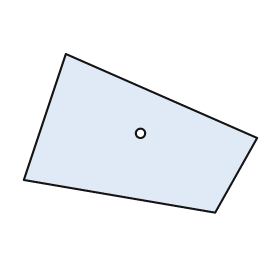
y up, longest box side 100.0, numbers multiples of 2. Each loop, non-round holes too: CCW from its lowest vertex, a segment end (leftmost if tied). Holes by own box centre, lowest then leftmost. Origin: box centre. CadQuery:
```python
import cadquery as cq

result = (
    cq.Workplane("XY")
    .moveTo(32.0, -34.0)
    .lineTo(50.0, -2.0)
    .lineTo(-32.0, 34.0)
    .lineTo(-50.0, -20.0)
    .close()
    .moveTo(0.0, 0.0)
    .circle(2.0)
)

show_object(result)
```